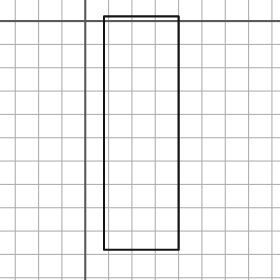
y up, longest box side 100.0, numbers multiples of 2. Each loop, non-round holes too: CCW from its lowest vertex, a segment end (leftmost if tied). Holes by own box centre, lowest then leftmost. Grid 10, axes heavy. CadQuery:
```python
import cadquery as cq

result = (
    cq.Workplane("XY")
    .moveTo(8.0, -98.0)
    .lineTo(40.0, -98.0)
    .lineTo(40.0, 2.0)
    .lineTo(8.0, 2.0)
    .close()
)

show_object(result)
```